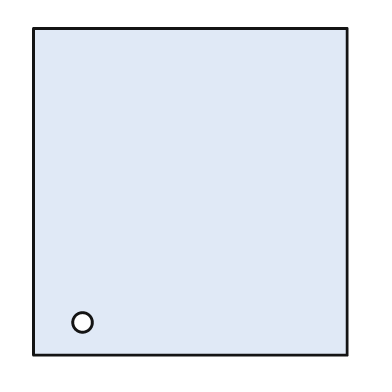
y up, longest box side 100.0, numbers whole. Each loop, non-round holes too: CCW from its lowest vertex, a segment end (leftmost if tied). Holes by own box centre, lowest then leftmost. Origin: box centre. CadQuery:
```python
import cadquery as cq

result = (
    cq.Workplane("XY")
    .moveTo(-48.0, -50.0)
    .lineTo(48.0, -50.0)
    .lineTo(48.0, 50.0)
    .lineTo(-48.0, 50.0)
    .close()
    .moveTo(-33.0, -40.0)
    .circle(3.0)
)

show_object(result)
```